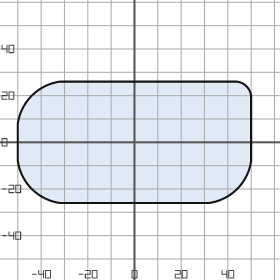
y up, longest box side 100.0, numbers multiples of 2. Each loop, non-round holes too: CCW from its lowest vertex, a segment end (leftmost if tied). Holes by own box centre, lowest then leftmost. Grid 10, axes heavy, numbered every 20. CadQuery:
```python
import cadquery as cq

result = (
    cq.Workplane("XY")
    .moveTo(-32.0, -26.0)
    .lineTo(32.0, -26.0)
    .threePointArc((44.0, -20.0), (50.0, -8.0))
    .lineTo(50.0, 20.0)
    .threePointArc((48.0, 24.0), (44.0, 26.0))
    .lineTo(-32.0, 26.0)
    .threePointArc((-44.0, 20.0), (-50.0, 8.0))
    .lineTo(-50.0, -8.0)
    .threePointArc((-44.0, -20.0), (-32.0, -26.0))
    .close()
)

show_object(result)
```